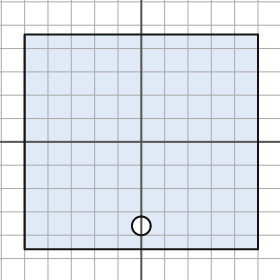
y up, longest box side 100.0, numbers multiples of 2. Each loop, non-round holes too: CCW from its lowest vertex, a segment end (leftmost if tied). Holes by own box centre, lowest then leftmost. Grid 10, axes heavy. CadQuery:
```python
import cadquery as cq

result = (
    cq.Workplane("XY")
    .moveTo(-50.0, -46.0)
    .lineTo(50.0, -46.0)
    .lineTo(50.0, 46.0)
    .lineTo(-50.0, 46.0)
    .close()
    .moveTo(0.0, -36.0)
    .circle(4.0)
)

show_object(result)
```